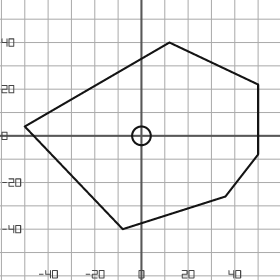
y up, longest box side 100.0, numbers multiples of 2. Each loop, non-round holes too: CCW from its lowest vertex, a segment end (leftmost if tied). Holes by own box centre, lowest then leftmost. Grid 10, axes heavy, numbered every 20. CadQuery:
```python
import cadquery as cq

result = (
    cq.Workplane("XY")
    .moveTo(-8.0, -40.0)
    .lineTo(36.0, -26.0)
    .lineTo(50.0, -8.0)
    .lineTo(50.0, 22.0)
    .lineTo(12.0, 40.0)
    .lineTo(-50.0, 4.0)
    .close()
    .moveTo(0.0, 0.0)
    .circle(4.0)
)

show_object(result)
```